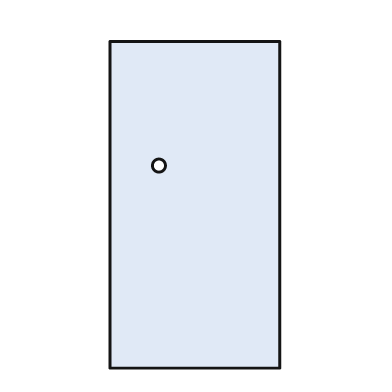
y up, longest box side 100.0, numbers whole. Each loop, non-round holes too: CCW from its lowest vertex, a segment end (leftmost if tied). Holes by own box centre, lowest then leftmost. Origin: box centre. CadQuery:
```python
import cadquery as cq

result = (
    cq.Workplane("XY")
    .moveTo(-26.0, -50.0)
    .lineTo(26.0, -50.0)
    .lineTo(26.0, 50.0)
    .lineTo(-26.0, 50.0)
    .close()
    .moveTo(-11.0, 12.0)
    .circle(2.0)
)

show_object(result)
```